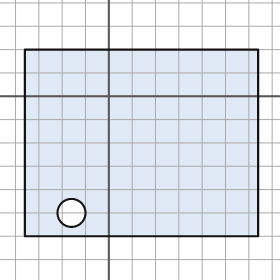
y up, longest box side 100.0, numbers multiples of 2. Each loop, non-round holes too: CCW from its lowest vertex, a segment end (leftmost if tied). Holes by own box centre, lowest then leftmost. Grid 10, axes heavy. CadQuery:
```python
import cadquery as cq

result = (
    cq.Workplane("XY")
    .moveTo(-36.0, -60.0)
    .lineTo(64.0, -60.0)
    .lineTo(64.0, 20.0)
    .lineTo(-36.0, 20.0)
    .close()
    .moveTo(-16.0, -50.0)
    .circle(6.0)
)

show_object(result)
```